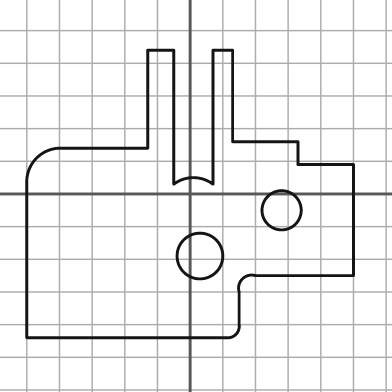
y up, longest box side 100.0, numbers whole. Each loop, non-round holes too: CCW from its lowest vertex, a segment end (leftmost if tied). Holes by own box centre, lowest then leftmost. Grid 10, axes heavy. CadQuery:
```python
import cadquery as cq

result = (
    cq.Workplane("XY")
    .moveTo(-50.0, -44.0)
    .lineTo(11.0, -44.0)
    .threePointArc((14.0, -43.0), (15.0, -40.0))
    .lineTo(15.0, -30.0)
    .threePointArc((16.0, -26.0), (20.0, -25.0))
    .lineTo(50.0, -25.0)
    .lineTo(50.0, 9.0)
    .lineTo(33.0, 9.0)
    .lineTo(33.0, 16.0)
    .lineTo(13.0, 16.0)
    .lineTo(13.0, 44.0)
    .lineTo(7.0, 44.0)
    .lineTo(7.0, 3.0)
    .threePointArc((1.0, 5.0), (-5.0, 3.0))
    .lineTo(-5.0, 44.0)
    .lineTo(-13.0, 44.0)
    .lineTo(-13.0, 14.0)
    .lineTo(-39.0, 14.0)
    .threePointArc((-47.0, 11.0), (-50.0, 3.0))
    .close()
    .moveTo(3.0, -19.0)
    .circle(7.0)
    .moveTo(28.0, -5.0)
    .circle(6.0)
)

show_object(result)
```